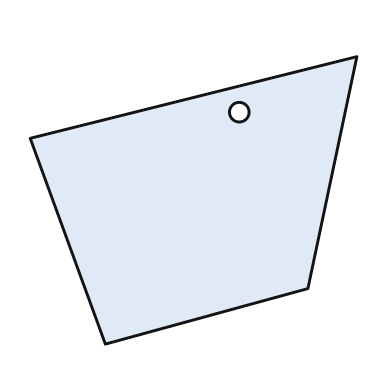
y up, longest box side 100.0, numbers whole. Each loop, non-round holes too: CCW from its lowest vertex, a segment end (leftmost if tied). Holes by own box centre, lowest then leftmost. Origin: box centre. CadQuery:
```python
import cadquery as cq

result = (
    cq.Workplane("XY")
    .moveTo(-27.0, -44.0)
    .lineTo(35.0, -27.0)
    .lineTo(50.0, 44.0)
    .lineTo(-50.0, 19.0)
    .close()
    .moveTo(14.0, 27.0)
    .circle(3.0)
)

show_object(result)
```